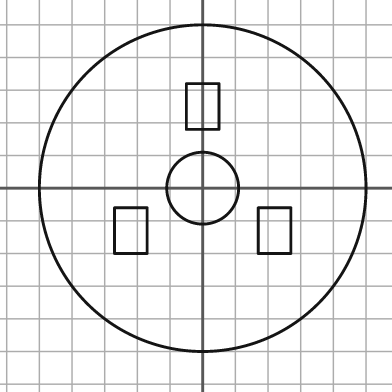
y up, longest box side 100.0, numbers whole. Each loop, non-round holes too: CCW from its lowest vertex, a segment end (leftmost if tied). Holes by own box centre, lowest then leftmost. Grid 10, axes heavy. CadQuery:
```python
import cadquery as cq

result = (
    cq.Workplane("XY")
    .moveTo(0.0, 0.0)
    .circle(50.0)
    .moveTo(-27.0, -20.0)
    .lineTo(-17.0, -20.0)
    .lineTo(-17.0, -6.0)
    .lineTo(-27.0, -6.0)
    .close()
    .moveTo(17.0, -20.0)
    .lineTo(27.0, -20.0)
    .lineTo(27.0, -6.0)
    .lineTo(17.0, -6.0)
    .close()
    .moveTo(0.0, 0.0)
    .circle(11.0)
    .moveTo(-5.0, 18.0)
    .lineTo(5.0, 18.0)
    .lineTo(5.0, 32.0)
    .lineTo(-5.0, 32.0)
    .close()
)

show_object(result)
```